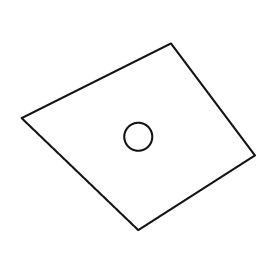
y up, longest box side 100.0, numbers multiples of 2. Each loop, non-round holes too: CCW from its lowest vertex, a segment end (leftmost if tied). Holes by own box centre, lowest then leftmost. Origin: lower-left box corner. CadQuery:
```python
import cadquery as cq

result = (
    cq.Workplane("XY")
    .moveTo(50.0, 0.0)
    .lineTo(100.0, 32.0)
    .lineTo(64.0, 80.0)
    .lineTo(0.0, 48.0)
    .close()
    .moveTo(50.0, 40.0)
    .circle(6.0)
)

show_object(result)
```